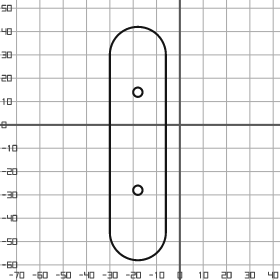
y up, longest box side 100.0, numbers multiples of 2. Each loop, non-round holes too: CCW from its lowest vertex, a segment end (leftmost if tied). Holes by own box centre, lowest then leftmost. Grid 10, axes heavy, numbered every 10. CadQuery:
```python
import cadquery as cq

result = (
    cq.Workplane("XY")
    .moveTo(-30.0, -46.0)
    .threePointArc((-18.0, -58.0), (-6.0, -46.0))
    .lineTo(-6.0, 30.0)
    .threePointArc((-18.0, 42.0), (-30.0, 30.0))
    .close()
    .moveTo(-18.0, -28.0)
    .circle(2.0)
    .moveTo(-18.0, 14.0)
    .circle(2.0)
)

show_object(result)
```